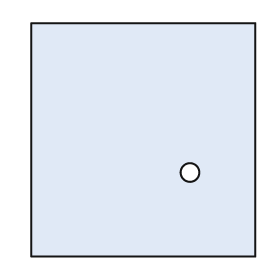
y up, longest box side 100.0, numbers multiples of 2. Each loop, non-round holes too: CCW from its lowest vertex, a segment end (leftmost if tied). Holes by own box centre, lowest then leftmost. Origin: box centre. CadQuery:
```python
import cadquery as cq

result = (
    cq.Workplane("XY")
    .moveTo(-48.0, -50.0)
    .lineTo(48.0, -50.0)
    .lineTo(48.0, 50.0)
    .lineTo(-48.0, 50.0)
    .close()
    .moveTo(20.0, -14.0)
    .circle(4.0)
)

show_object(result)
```